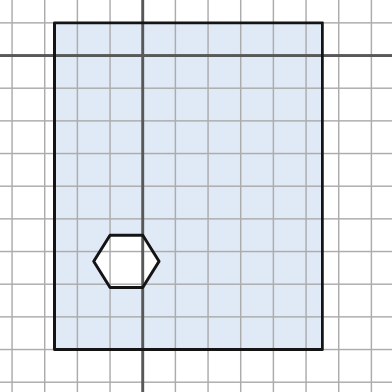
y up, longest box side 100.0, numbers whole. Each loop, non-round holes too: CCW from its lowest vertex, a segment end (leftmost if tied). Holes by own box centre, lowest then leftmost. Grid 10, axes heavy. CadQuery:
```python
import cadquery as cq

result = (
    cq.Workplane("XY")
    .moveTo(-27.0, -90.0)
    .lineTo(55.0, -90.0)
    .lineTo(55.0, 10.0)
    .lineTo(-27.0, 10.0)
    .close()
    .moveTo(-10.0, -71.0)
    .lineTo(0.0, -71.0)
    .lineTo(5.0, -63.0)
    .lineTo(0.0, -55.0)
    .lineTo(-10.0, -55.0)
    .lineTo(-15.0, -63.0)
    .close()
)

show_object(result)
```